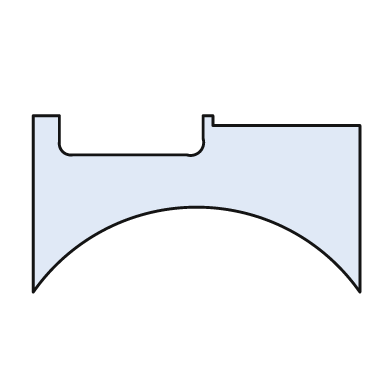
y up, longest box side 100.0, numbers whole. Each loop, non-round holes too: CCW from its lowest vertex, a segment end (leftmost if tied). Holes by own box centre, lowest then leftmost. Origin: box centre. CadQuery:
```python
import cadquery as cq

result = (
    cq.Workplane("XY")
    .moveTo(-50.0, -27.0)
    .threePointArc((0.0, -1.0), (50.0, -27.0))
    .lineTo(50.0, 24.0)
    .lineTo(5.0, 24.0)
    .lineTo(5.0, 27.0)
    .lineTo(2.0, 27.0)
    .lineTo(2.0, 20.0)
    .threePointArc((1.0, 16.0), (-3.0, 15.0))
    .lineTo(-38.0, 15.0)
    .threePointArc((-41.0, 16.0), (-42.0, 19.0))
    .lineTo(-42.0, 27.0)
    .lineTo(-50.0, 27.0)
    .close()
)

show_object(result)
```